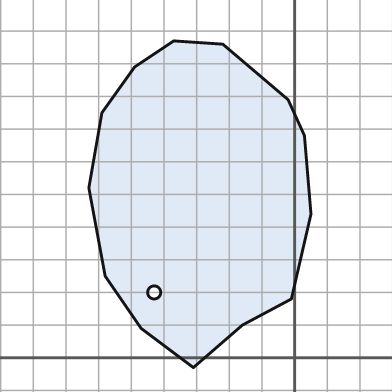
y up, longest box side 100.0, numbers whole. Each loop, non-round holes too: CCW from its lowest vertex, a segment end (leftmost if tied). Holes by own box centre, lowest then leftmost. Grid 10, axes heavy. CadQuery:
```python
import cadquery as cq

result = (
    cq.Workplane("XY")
    .moveTo(-31.0, -3.0)
    .lineTo(-16.0, 10.0)
    .lineTo(-1.0, 18.0)
    .lineTo(5.0, 44.0)
    .lineTo(3.0, 68.0)
    .lineTo(-2.0, 79.0)
    .lineTo(-22.0, 96.0)
    .lineTo(-37.0, 97.0)
    .lineTo(-49.0, 89.0)
    .lineTo(-59.0, 75.0)
    .lineTo(-63.0, 52.0)
    .lineTo(-58.0, 25.0)
    .lineTo(-47.0, 9.0)
    .close()
    .moveTo(-43.0, 20.0)
    .circle(2.0)
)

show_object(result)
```